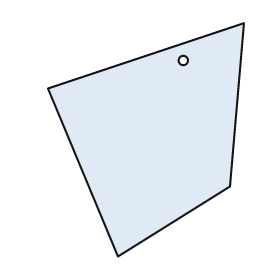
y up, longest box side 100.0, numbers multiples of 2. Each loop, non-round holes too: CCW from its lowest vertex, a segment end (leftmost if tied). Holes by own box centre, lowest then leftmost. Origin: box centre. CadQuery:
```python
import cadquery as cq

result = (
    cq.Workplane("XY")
    .moveTo(-12.0, -50.0)
    .lineTo(36.0, -20.0)
    .lineTo(42.0, 50.0)
    .lineTo(-42.0, 22.0)
    .close()
    .moveTo(16.0, 34.0)
    .circle(2.0)
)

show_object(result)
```